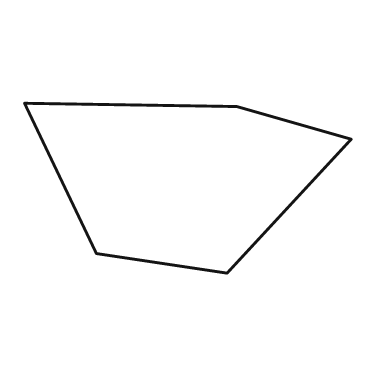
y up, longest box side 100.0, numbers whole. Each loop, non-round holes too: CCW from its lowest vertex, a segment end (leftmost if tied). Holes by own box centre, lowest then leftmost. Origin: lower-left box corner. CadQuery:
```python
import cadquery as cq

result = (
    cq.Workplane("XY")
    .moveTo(62.0, 0.0)
    .lineTo(100.0, 41.0)
    .lineTo(65.0, 51.0)
    .lineTo(0.0, 52.0)
    .lineTo(22.0, 6.0)
    .close()
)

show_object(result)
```